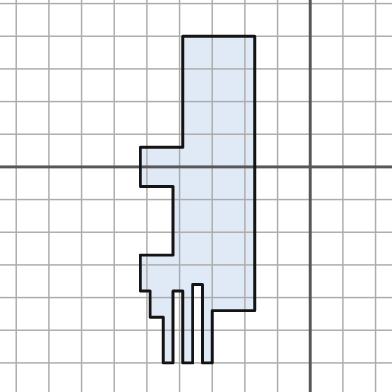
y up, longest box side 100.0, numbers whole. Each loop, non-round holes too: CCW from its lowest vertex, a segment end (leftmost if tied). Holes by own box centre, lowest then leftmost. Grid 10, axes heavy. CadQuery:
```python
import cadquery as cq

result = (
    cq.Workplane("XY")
    .moveTo(-45.0, -60.0)
    .lineTo(-42.0, -60.0)
    .lineTo(-42.0, -38.0)
    .lineTo(-39.0, -38.0)
    .lineTo(-39.0, -60.0)
    .lineTo(-36.0, -60.0)
    .lineTo(-36.0, -36.0)
    .lineTo(-33.0, -36.0)
    .lineTo(-33.0, -60.0)
    .lineTo(-30.0, -60.0)
    .lineTo(-30.0, -44.0)
    .lineTo(-17.0, -44.0)
    .lineTo(-17.0, 40.0)
    .lineTo(-39.0, 40.0)
    .lineTo(-39.0, 6.0)
    .lineTo(-52.0, 6.0)
    .lineTo(-52.0, -6.0)
    .lineTo(-42.0, -6.0)
    .lineTo(-42.0, -27.0)
    .lineTo(-52.0, -27.0)
    .lineTo(-52.0, -38.0)
    .lineTo(-49.0, -38.0)
    .lineTo(-49.0, -46.0)
    .lineTo(-45.0, -46.0)
    .close()
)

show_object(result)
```